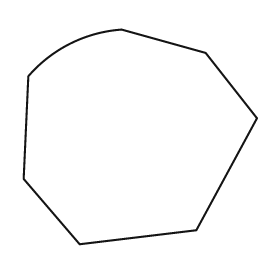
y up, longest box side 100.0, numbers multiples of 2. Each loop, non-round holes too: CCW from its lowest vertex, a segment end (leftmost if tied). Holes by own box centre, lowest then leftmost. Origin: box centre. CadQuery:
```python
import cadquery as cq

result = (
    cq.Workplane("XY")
    .moveTo(-26.0, -46.0)
    .lineTo(24.0, -40.0)
    .lineTo(50.0, 8.0)
    .lineTo(28.0, 36.0)
    .lineTo(-8.0, 46.0)
    .threePointArc((-30.0, 40.0), (-48.0, 26.0))
    .lineTo(-50.0, -18.0)
    .close()
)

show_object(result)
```